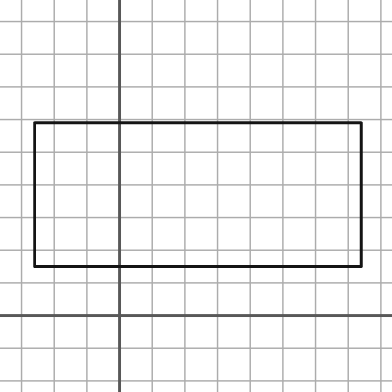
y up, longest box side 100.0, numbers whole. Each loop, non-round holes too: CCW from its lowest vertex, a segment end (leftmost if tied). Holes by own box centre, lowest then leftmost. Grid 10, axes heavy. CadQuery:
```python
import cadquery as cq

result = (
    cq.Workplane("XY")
    .moveTo(-26.0, 15.0)
    .lineTo(74.0, 15.0)
    .lineTo(74.0, 59.0)
    .lineTo(-26.0, 59.0)
    .close()
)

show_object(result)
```